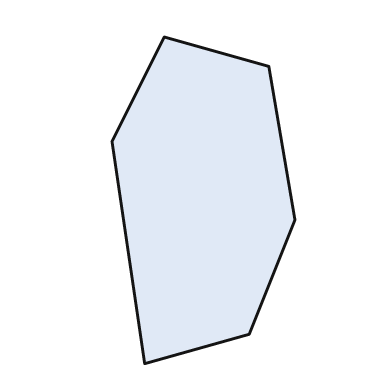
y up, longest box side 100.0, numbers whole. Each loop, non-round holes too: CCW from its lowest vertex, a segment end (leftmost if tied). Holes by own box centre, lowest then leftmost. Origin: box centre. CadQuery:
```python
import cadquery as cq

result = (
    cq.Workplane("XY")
    .moveTo(-18.0, -50.0)
    .lineTo(14.0, -41.0)
    .lineTo(28.0, -6.0)
    .lineTo(20.0, 41.0)
    .lineTo(-12.0, 50.0)
    .lineTo(-28.0, 18.0)
    .close()
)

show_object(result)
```